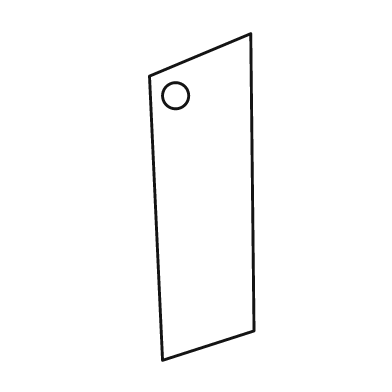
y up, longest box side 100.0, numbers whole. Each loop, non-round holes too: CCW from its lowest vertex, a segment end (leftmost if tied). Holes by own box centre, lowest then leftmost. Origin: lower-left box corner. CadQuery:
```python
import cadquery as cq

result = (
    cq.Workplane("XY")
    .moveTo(4.0, 0.0)
    .lineTo(32.0, 9.0)
    .lineTo(31.0, 100.0)
    .lineTo(0.0, 87.0)
    .close()
    .moveTo(8.0, 81.0)
    .circle(4.0)
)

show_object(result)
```